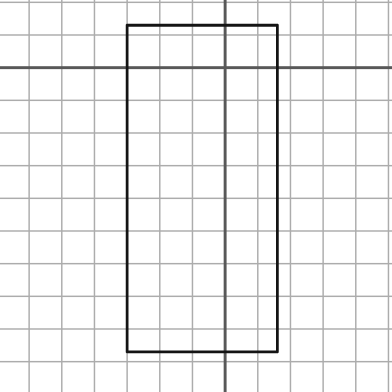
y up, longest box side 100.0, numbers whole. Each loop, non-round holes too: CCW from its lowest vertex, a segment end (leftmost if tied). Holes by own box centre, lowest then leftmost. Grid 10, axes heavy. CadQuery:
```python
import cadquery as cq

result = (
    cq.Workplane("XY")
    .moveTo(-30.0, -87.0)
    .lineTo(16.0, -87.0)
    .lineTo(16.0, 13.0)
    .lineTo(-30.0, 13.0)
    .close()
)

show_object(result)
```